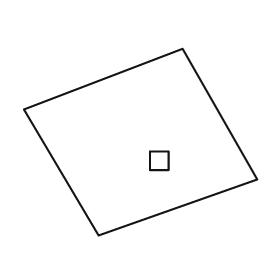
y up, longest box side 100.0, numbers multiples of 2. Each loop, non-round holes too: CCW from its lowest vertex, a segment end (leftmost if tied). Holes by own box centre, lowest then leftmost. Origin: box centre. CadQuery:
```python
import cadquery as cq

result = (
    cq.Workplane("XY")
    .moveTo(-18.0, -40.0)
    .lineTo(50.0, -16.0)
    .lineTo(18.0, 40.0)
    .lineTo(-50.0, 14.0)
    .close()
    .moveTo(4.0, -12.0)
    .lineTo(12.0, -12.0)
    .lineTo(12.0, -4.0)
    .lineTo(4.0, -4.0)
    .close()
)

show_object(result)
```